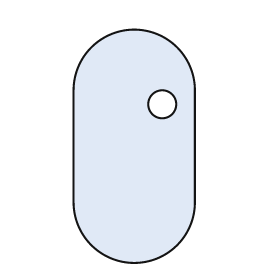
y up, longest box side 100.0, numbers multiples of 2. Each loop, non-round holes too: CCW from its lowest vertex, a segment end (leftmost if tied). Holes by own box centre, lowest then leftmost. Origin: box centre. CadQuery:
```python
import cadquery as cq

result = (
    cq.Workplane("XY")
    .moveTo(-26.0, -24.0)
    .threePointArc((0.0, -50.0), (26.0, -24.0))
    .lineTo(26.0, 24.0)
    .threePointArc((0.0, 50.0), (-26.0, 24.0))
    .close()
    .moveTo(12.0, 18.0)
    .circle(6.0)
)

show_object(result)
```